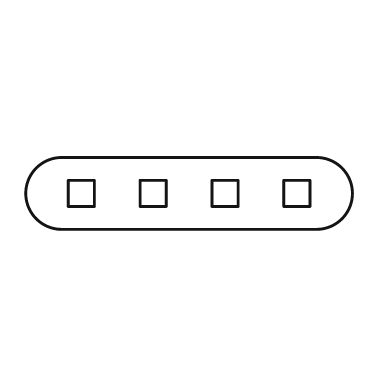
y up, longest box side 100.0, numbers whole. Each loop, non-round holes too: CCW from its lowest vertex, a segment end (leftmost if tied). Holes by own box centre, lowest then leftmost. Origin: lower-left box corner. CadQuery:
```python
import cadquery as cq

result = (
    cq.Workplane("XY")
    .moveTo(11.0, 0.0)
    .lineTo(89.0, 0.0)
    .threePointArc((100.0, 11.0), (89.0, 22.0))
    .lineTo(11.0, 22.0)
    .threePointArc((0.0, 11.0), (11.0, 0.0))
    .close()
    .moveTo(13.0, 7.0)
    .lineTo(21.0, 7.0)
    .lineTo(21.0, 15.0)
    .lineTo(13.0, 15.0)
    .close()
    .moveTo(35.0, 7.0)
    .lineTo(43.0, 7.0)
    .lineTo(43.0, 15.0)
    .lineTo(35.0, 15.0)
    .close()
    .moveTo(57.0, 7.0)
    .lineTo(65.0, 7.0)
    .lineTo(65.0, 15.0)
    .lineTo(57.0, 15.0)
    .close()
    .moveTo(79.0, 7.0)
    .lineTo(87.0, 7.0)
    .lineTo(87.0, 15.0)
    .lineTo(79.0, 15.0)
    .close()
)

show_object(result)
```